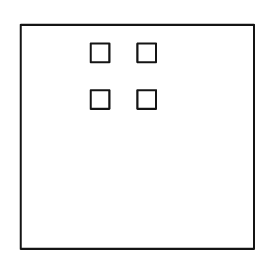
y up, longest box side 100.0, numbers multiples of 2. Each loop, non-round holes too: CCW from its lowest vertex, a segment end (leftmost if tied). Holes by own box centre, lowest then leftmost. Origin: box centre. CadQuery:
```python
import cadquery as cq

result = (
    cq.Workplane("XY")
    .moveTo(-50.0, -48.0)
    .lineTo(50.0, -48.0)
    .lineTo(50.0, 48.0)
    .lineTo(-50.0, 48.0)
    .close()
    .moveTo(-20.0, 12.0)
    .lineTo(-12.0, 12.0)
    .lineTo(-12.0, 20.0)
    .lineTo(-20.0, 20.0)
    .close()
    .moveTo(0.0, 12.0)
    .lineTo(8.0, 12.0)
    .lineTo(8.0, 20.0)
    .lineTo(0.0, 20.0)
    .close()
    .moveTo(-20.0, 32.0)
    .lineTo(-12.0, 32.0)
    .lineTo(-12.0, 40.0)
    .lineTo(-20.0, 40.0)
    .close()
    .moveTo(0.0, 32.0)
    .lineTo(8.0, 32.0)
    .lineTo(8.0, 40.0)
    .lineTo(0.0, 40.0)
    .close()
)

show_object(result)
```